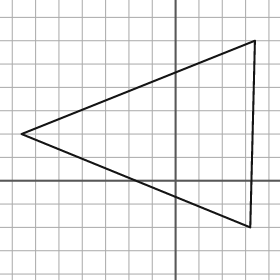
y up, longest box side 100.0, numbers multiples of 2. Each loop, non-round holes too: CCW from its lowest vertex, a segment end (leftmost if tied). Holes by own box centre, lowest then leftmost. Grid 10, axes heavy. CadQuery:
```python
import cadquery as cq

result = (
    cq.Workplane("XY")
    .moveTo(32.0, -20.0)
    .lineTo(34.0, 60.0)
    .lineTo(-66.0, 20.0)
    .close()
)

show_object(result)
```